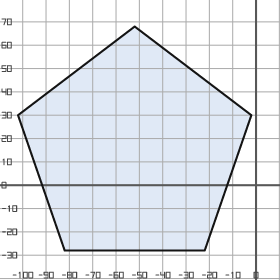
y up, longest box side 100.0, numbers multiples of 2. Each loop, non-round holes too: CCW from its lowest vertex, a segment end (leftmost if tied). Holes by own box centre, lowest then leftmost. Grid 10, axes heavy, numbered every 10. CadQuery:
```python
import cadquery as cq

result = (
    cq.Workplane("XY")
    .moveTo(-82.0, -28.0)
    .lineTo(-22.0, -28.0)
    .lineTo(-2.0, 30.0)
    .lineTo(-52.0, 68.0)
    .lineTo(-102.0, 30.0)
    .close()
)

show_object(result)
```